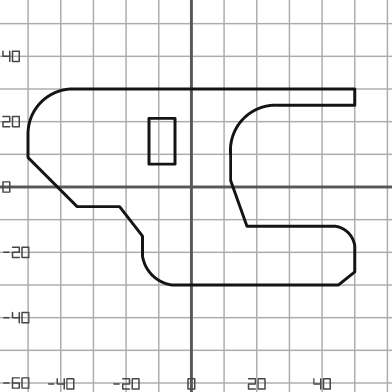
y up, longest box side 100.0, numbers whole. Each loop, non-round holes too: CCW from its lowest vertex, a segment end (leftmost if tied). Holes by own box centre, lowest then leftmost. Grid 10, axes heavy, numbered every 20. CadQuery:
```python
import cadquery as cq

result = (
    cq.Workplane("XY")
    .moveTo(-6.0, -30.0)
    .lineTo(45.0, -30.0)
    .lineTo(50.0, -26.0)
    .lineTo(50.0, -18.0)
    .threePointArc((48.0, -14.0), (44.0, -12.0))
    .lineTo(17.0, -12.0)
    .lineTo(12.0, 2.0)
    .lineTo(12.0, 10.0)
    .threePointArc((16.0, 21.0), (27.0, 25.0))
    .lineTo(50.0, 25.0)
    .lineTo(50.0, 30.0)
    .lineTo(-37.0, 30.0)
    .threePointArc((-46.0, 26.0), (-50.0, 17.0))
    .lineTo(-50.0, 9.0)
    .lineTo(-35.0, -6.0)
    .lineTo(-22.0, -6.0)
    .lineTo(-15.0, -15.0)
    .lineTo(-15.0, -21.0)
    .threePointArc((-12.0, -27.0), (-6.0, -30.0))
    .close()
    .moveTo(-13.0, 7.0)
    .lineTo(-5.0, 7.0)
    .lineTo(-5.0, 21.0)
    .lineTo(-13.0, 21.0)
    .close()
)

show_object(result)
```